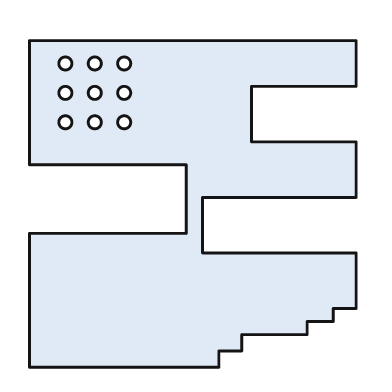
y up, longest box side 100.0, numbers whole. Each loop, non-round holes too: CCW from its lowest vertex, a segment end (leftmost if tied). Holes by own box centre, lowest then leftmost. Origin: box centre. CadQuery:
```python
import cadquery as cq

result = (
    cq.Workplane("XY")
    .moveTo(-50.0, -50.0)
    .lineTo(8.0, -50.0)
    .lineTo(8.0, -45.0)
    .lineTo(15.0, -45.0)
    .lineTo(15.0, -40.0)
    .lineTo(35.0, -40.0)
    .lineTo(35.0, -36.0)
    .lineTo(43.0, -36.0)
    .lineTo(43.0, -32.0)
    .lineTo(50.0, -32.0)
    .lineTo(50.0, -15.0)
    .lineTo(3.0, -15.0)
    .lineTo(3.0, 2.0)
    .lineTo(50.0, 2.0)
    .lineTo(50.0, 19.0)
    .lineTo(18.0, 19.0)
    .lineTo(18.0, 36.0)
    .lineTo(50.0, 36.0)
    .lineTo(50.0, 50.0)
    .lineTo(-50.0, 50.0)
    .lineTo(-50.0, 12.0)
    .lineTo(-2.0, 12.0)
    .lineTo(-2.0, -9.0)
    .lineTo(-50.0, -9.0)
    .close()
    .moveTo(-39.0, 25.0)
    .circle(2.0)
    .moveTo(-30.0, 25.0)
    .circle(2.0)
    .moveTo(-21.0, 25.0)
    .circle(2.0)
    .moveTo(-39.0, 34.0)
    .circle(2.0)
    .moveTo(-30.0, 34.0)
    .circle(2.0)
    .moveTo(-21.0, 34.0)
    .circle(2.0)
    .moveTo(-39.0, 43.0)
    .circle(2.0)
    .moveTo(-30.0, 43.0)
    .circle(2.0)
    .moveTo(-21.0, 43.0)
    .circle(2.0)
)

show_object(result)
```